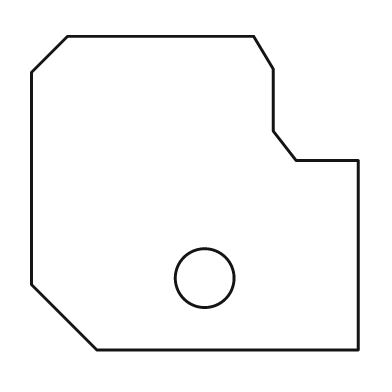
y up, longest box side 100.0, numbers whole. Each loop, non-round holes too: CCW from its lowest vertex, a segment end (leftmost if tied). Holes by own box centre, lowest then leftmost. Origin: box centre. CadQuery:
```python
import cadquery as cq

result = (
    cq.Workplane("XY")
    .moveTo(-30.0, -48.0)
    .lineTo(50.0, -48.0)
    .lineTo(50.0, 10.0)
    .lineTo(31.0, 10.0)
    .lineTo(24.0, 19.0)
    .lineTo(24.0, 38.0)
    .lineTo(18.0, 48.0)
    .lineTo(-39.0, 48.0)
    .lineTo(-50.0, 37.0)
    .lineTo(-50.0, -28.0)
    .close()
    .moveTo(3.0, -26.0)
    .circle(9.0)
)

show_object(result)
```